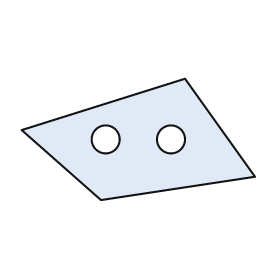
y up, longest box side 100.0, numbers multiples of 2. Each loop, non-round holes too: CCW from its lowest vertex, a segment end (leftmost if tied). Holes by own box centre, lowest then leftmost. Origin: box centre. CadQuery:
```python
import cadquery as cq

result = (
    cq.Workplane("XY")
    .moveTo(-16.0, -26.0)
    .lineTo(50.0, -16.0)
    .lineTo(20.0, 26.0)
    .lineTo(-50.0, 4.0)
    .close()
    .moveTo(-14.0, 0.0)
    .circle(6.0)
    .moveTo(14.0, 0.0)
    .circle(6.0)
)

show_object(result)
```